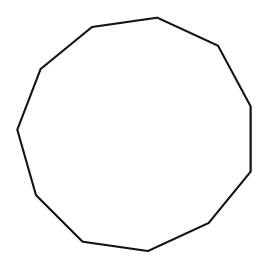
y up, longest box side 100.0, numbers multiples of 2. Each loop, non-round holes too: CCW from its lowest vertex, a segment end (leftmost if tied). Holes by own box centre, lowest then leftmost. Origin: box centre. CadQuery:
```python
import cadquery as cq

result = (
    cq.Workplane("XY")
    .moveTo(6.0, -50.0)
    .lineTo(32.0, -38.0)
    .lineTo(50.0, -16.0)
    .lineTo(50.0, 12.0)
    .lineTo(36.0, 38.0)
    .lineTo(10.0, 50.0)
    .lineTo(-18.0, 46.0)
    .lineTo(-40.0, 28.0)
    .lineTo(-50.0, 2.0)
    .lineTo(-42.0, -26.0)
    .lineTo(-22.0, -46.0)
    .close()
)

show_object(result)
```